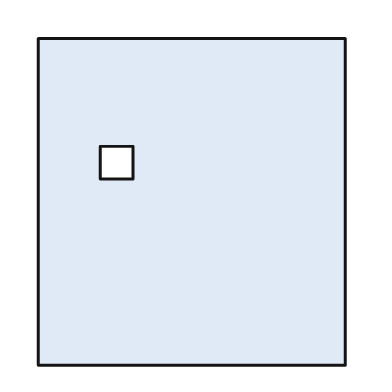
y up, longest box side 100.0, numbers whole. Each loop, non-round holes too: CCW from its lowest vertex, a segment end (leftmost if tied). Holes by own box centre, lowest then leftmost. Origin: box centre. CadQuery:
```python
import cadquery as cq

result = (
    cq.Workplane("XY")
    .moveTo(-47.0, -50.0)
    .lineTo(47.0, -50.0)
    .lineTo(47.0, 50.0)
    .lineTo(-47.0, 50.0)
    .close()
    .moveTo(-28.0, 7.0)
    .lineTo(-18.0, 7.0)
    .lineTo(-18.0, 17.0)
    .lineTo(-28.0, 17.0)
    .close()
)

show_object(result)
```